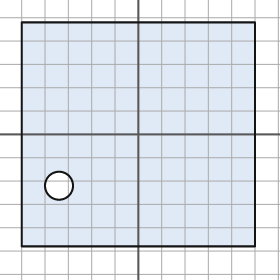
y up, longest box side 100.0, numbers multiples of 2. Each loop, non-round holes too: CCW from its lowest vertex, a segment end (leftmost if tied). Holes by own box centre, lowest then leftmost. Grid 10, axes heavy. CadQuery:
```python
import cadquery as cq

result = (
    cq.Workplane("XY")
    .moveTo(-50.0, -48.0)
    .lineTo(50.0, -48.0)
    .lineTo(50.0, 48.0)
    .lineTo(-50.0, 48.0)
    .close()
    .moveTo(-34.0, -22.0)
    .circle(6.0)
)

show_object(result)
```